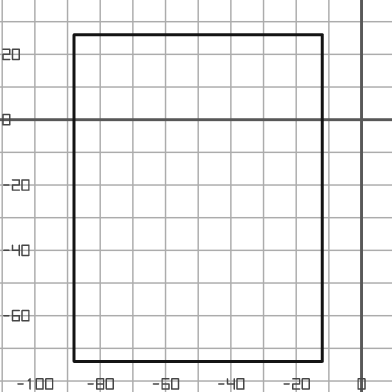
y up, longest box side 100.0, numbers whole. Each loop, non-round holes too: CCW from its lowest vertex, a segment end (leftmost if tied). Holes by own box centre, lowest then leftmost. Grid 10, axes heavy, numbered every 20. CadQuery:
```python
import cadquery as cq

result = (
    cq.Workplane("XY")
    .moveTo(-88.0, -74.0)
    .lineTo(-12.0, -74.0)
    .lineTo(-12.0, 26.0)
    .lineTo(-88.0, 26.0)
    .close()
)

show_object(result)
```